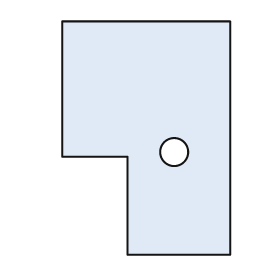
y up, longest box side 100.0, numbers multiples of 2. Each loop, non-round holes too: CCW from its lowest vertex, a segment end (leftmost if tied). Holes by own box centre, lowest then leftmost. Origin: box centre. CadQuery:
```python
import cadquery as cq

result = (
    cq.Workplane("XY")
    .moveTo(-8.0, -50.0)
    .lineTo(36.0, -50.0)
    .lineTo(36.0, 50.0)
    .lineTo(-36.0, 50.0)
    .lineTo(-36.0, -8.0)
    .lineTo(-8.0, -8.0)
    .close()
    .moveTo(12.0, -6.0)
    .circle(6.0)
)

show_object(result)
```